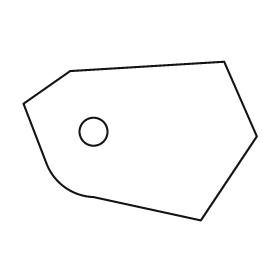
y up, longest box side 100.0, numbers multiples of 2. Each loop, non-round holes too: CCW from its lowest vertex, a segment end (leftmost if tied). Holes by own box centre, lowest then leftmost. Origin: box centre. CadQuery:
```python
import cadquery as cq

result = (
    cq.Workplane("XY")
    .moveTo(26.0, -34.0)
    .lineTo(50.0, 2.0)
    .lineTo(36.0, 34.0)
    .lineTo(-30.0, 30.0)
    .lineTo(-50.0, 16.0)
    .lineTo(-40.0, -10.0)
    .threePointArc((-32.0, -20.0), (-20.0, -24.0))
    .close()
    .moveTo(-20.0, 4.0)
    .circle(6.0)
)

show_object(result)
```